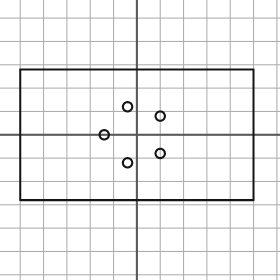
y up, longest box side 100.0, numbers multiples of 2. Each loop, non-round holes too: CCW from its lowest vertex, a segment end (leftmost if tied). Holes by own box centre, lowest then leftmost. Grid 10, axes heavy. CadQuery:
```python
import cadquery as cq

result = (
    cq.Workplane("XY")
    .moveTo(-50.0, -28.0)
    .lineTo(50.0, -28.0)
    .lineTo(50.0, 28.0)
    .lineTo(-50.0, 28.0)
    .close()
    .moveTo(-4.0, -12.0)
    .circle(2.0)
    .moveTo(10.0, -8.0)
    .circle(2.0)
    .moveTo(-14.0, 0.0)
    .circle(2.0)
    .moveTo(10.0, 8.0)
    .circle(2.0)
    .moveTo(-4.0, 12.0)
    .circle(2.0)
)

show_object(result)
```